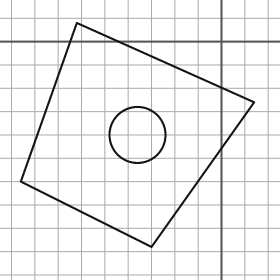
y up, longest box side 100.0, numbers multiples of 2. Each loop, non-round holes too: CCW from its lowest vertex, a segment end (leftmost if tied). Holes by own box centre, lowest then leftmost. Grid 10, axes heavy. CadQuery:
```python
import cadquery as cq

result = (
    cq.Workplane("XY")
    .moveTo(-30.0, -88.0)
    .lineTo(14.0, -26.0)
    .lineTo(-62.0, 8.0)
    .lineTo(-86.0, -60.0)
    .close()
    .moveTo(-36.0, -40.0)
    .circle(12.0)
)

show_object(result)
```